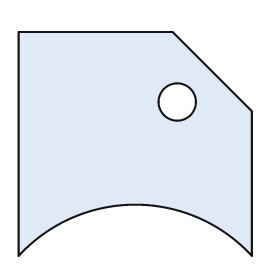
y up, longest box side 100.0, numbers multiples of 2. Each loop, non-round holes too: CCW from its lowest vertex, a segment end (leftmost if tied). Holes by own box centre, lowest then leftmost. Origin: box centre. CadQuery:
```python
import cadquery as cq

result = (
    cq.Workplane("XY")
    .moveTo(-50.0, -48.0)
    .threePointArc((0.0, -26.0), (50.0, -48.0))
    .lineTo(50.0, 14.0)
    .lineTo(16.0, 48.0)
    .lineTo(-50.0, 48.0)
    .close()
    .moveTo(18.0, 18.0)
    .circle(8.0)
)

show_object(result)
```